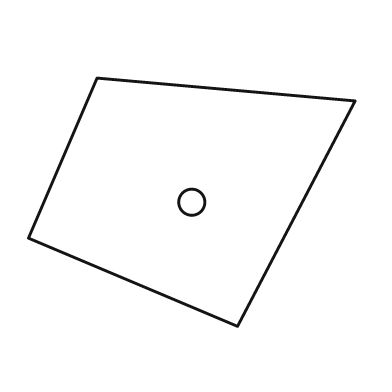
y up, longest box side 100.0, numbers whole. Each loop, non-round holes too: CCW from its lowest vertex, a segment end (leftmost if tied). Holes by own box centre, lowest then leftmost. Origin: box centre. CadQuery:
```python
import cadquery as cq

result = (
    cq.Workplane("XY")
    .moveTo(14.0, -38.0)
    .lineTo(50.0, 31.0)
    .lineTo(-29.0, 38.0)
    .lineTo(-50.0, -11.0)
    .close()
    .moveTo(0.0, 0.0)
    .circle(4.0)
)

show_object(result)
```